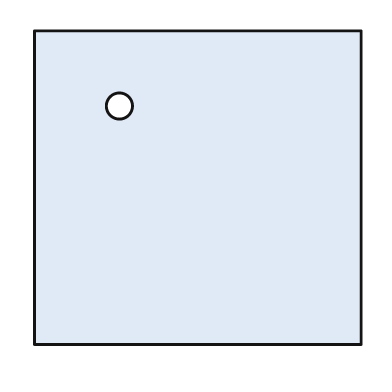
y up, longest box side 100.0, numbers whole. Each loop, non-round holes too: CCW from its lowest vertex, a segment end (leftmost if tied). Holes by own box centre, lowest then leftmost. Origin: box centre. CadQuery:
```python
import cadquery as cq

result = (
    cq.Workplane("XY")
    .moveTo(-50.0, -48.0)
    .lineTo(50.0, -48.0)
    .lineTo(50.0, 48.0)
    .lineTo(-50.0, 48.0)
    .close()
    .moveTo(-24.0, 25.0)
    .circle(4.0)
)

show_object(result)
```